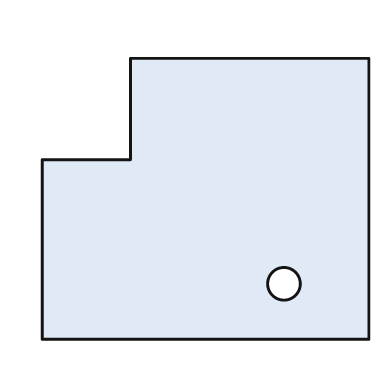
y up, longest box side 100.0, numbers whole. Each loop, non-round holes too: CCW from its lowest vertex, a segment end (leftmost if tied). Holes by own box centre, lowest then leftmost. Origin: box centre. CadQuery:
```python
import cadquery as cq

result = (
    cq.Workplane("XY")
    .moveTo(-50.0, -43.0)
    .lineTo(50.0, -43.0)
    .lineTo(50.0, 43.0)
    .lineTo(-23.0, 43.0)
    .lineTo(-23.0, 12.0)
    .lineTo(-50.0, 12.0)
    .close()
    .moveTo(24.0, -26.0)
    .circle(5.0)
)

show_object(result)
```